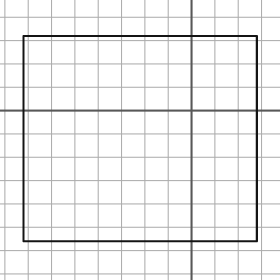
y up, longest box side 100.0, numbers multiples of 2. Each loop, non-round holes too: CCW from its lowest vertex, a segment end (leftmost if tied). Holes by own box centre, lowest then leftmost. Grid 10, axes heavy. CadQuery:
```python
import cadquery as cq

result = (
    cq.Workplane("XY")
    .moveTo(-72.0, -56.0)
    .lineTo(28.0, -56.0)
    .lineTo(28.0, 32.0)
    .lineTo(-72.0, 32.0)
    .close()
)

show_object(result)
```